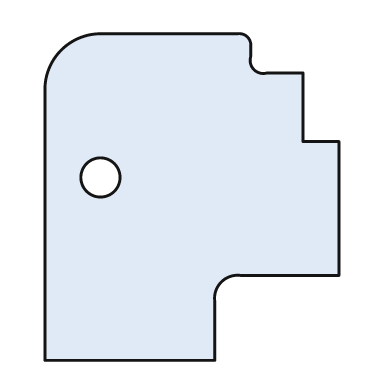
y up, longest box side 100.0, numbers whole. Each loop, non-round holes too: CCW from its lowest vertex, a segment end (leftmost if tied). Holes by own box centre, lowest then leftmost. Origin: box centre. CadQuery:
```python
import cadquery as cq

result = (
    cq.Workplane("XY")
    .moveTo(-45.0, -50.0)
    .lineTo(7.0, -50.0)
    .lineTo(7.0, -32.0)
    .threePointArc((9.0, -26.0), (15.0, -24.0))
    .lineTo(45.0, -24.0)
    .lineTo(45.0, 17.0)
    .lineTo(34.0, 17.0)
    .lineTo(34.0, 38.0)
    .lineTo(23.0, 38.0)
    .threePointArc((19.0, 39.0), (18.0, 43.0))
    .lineTo(18.0, 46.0)
    .threePointArc((17.0, 49.0), (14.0, 50.0))
    .lineTo(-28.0, 50.0)
    .threePointArc((-40.0, 45.0), (-45.0, 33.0))
    .close()
    .moveTo(-28.0, 6.0)
    .circle(6.0)
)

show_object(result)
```